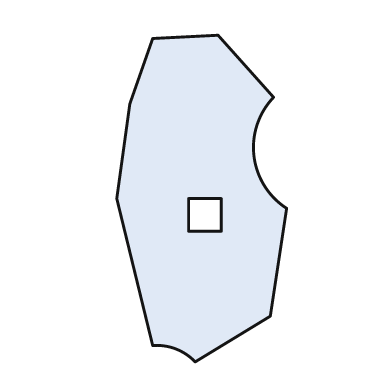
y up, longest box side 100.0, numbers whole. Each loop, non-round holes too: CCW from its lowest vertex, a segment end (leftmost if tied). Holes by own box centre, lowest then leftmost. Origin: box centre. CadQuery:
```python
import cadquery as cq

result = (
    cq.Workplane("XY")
    .moveTo(-2.0, -50.0)
    .lineTo(21.0, -36.0)
    .lineTo(26.0, -3.0)
    .threePointArc((16.0, 13.0), (22.0, 31.0))
    .lineTo(5.0, 50.0)
    .lineTo(-15.0, 49.0)
    .lineTo(-22.0, 29.0)
    .lineTo(-26.0, 0.0)
    .lineTo(-15.0, -45.0)
    .threePointArc((-8.0, -46.0), (-2.0, -50.0))
    .close()
    .moveTo(-4.0, -10.0)
    .lineTo(6.0, -10.0)
    .lineTo(6.0, 0.0)
    .lineTo(-4.0, 0.0)
    .close()
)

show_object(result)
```